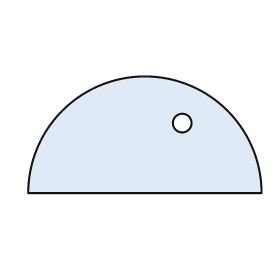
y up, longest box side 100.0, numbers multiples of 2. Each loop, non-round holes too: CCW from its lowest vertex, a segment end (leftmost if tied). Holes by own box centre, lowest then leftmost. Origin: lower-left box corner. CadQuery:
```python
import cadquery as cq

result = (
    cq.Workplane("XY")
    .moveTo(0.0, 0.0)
    .lineTo(100.0, 0.0)
    .threePointArc((50.0, 50.0), (0.0, 0.0))
    .close()
    .moveTo(66.0, 30.0)
    .circle(4.0)
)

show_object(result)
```